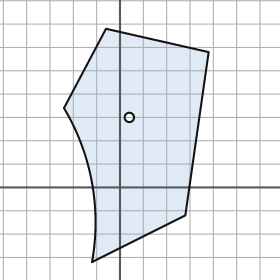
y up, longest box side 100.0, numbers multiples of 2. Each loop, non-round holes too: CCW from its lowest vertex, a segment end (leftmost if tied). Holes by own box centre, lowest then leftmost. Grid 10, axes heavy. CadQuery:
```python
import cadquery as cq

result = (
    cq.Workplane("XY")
    .moveTo(-12.0, -32.0)
    .lineTo(28.0, -12.0)
    .lineTo(38.0, 58.0)
    .lineTo(-6.0, 68.0)
    .lineTo(-24.0, 34.0)
    .threePointArc((-12.0, 2.0), (-12.0, -32.0))
    .close()
    .moveTo(4.0, 30.0)
    .circle(2.0)
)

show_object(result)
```